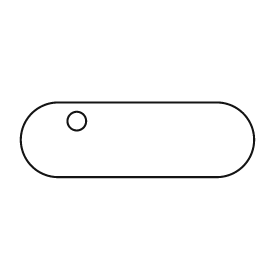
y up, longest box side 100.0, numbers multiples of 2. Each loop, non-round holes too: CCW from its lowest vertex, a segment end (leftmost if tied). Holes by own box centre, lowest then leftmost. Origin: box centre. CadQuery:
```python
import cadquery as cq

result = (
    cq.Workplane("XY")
    .moveTo(-34.0, -16.0)
    .lineTo(34.0, -16.0)
    .threePointArc((50.0, 0.0), (34.0, 16.0))
    .lineTo(-34.0, 16.0)
    .threePointArc((-50.0, 0.0), (-34.0, -16.0))
    .close()
    .moveTo(-26.0, 8.0)
    .circle(4.0)
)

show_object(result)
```